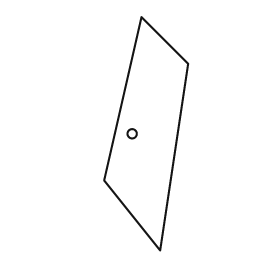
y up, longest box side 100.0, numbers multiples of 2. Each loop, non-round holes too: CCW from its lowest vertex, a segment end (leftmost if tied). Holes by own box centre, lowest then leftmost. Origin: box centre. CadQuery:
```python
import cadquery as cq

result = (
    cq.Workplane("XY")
    .moveTo(6.0, -50.0)
    .lineTo(18.0, 30.0)
    .lineTo(-2.0, 50.0)
    .lineTo(-18.0, -20.0)
    .close()
    .moveTo(-6.0, 0.0)
    .circle(2.0)
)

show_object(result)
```